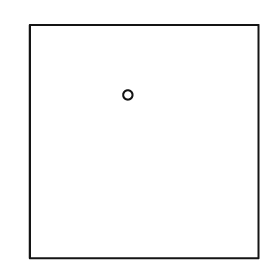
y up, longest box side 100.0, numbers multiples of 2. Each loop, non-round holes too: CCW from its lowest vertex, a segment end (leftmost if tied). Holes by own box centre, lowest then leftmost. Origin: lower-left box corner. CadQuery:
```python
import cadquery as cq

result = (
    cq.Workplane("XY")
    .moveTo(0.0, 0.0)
    .lineTo(98.0, 0.0)
    .lineTo(98.0, 100.0)
    .lineTo(0.0, 100.0)
    .close()
    .moveTo(42.0, 70.0)
    .circle(2.0)
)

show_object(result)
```